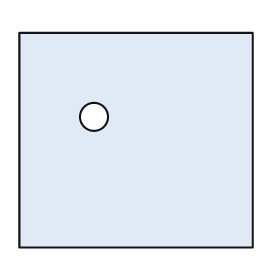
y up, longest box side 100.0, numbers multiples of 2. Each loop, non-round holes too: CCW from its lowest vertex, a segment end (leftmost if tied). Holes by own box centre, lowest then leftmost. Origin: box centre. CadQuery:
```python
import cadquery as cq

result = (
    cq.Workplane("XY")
    .moveTo(-50.0, -46.0)
    .lineTo(50.0, -46.0)
    .lineTo(50.0, 46.0)
    .lineTo(-50.0, 46.0)
    .close()
    .moveTo(-18.0, 10.0)
    .circle(6.0)
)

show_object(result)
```